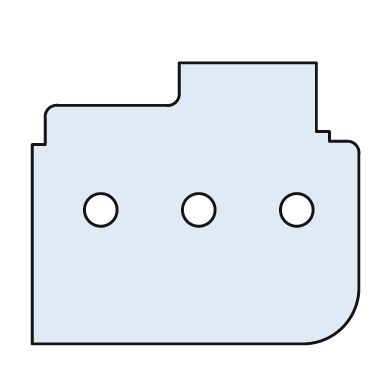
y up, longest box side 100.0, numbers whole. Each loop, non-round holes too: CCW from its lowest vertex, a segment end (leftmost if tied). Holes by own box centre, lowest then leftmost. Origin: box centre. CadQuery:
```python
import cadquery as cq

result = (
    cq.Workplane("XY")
    .moveTo(-50.0, -43.0)
    .lineTo(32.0, -43.0)
    .threePointArc((45.0, -38.0), (50.0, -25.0))
    .lineTo(50.0, 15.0)
    .threePointArc((49.0, 18.0), (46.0, 19.0))
    .lineTo(41.0, 19.0)
    .lineTo(41.0, 22.0)
    .lineTo(37.0, 22.0)
    .lineTo(37.0, 43.0)
    .lineTo(-5.0, 43.0)
    .lineTo(-5.0, 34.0)
    .threePointArc((-6.0, 31.0), (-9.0, 30.0))
    .lineTo(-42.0, 30.0)
    .threePointArc((-45.0, 29.0), (-46.0, 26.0))
    .lineTo(-46.0, 18.0)
    .lineTo(-50.0, 18.0)
    .close()
    .moveTo(-29.0, -2.0)
    .circle(5.0)
    .moveTo(1.0, -2.0)
    .circle(5.0)
    .moveTo(31.0, -2.0)
    .circle(5.0)
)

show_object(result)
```